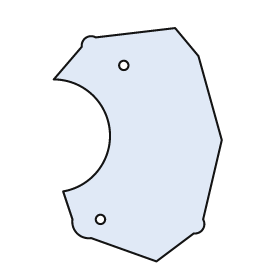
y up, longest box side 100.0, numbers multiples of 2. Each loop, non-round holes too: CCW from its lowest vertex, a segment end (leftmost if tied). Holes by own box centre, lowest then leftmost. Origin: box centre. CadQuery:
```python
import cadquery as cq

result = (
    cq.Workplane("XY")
    .moveTo(8.0, -50.0)
    .lineTo(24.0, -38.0)
    .threePointArc((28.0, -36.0), (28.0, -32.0))
    .lineTo(36.0, 2.0)
    .lineTo(26.0, 38.0)
    .lineTo(16.0, 50.0)
    .lineTo(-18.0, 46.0)
    .threePointArc((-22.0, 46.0), (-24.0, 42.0))
    .lineTo(-36.0, 28.0)
    .threePointArc((-12.0, 6.0), (-32.0, -20.0))
    .lineTo(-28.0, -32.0)
    .threePointArc((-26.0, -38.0), (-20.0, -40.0))
    .close()
    .moveTo(-16.0, -32.0)
    .circle(2.0)
    .moveTo(-6.0, 34.0)
    .circle(2.0)
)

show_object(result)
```